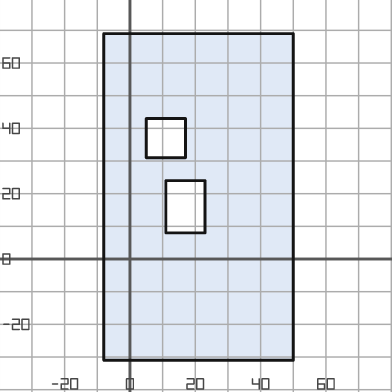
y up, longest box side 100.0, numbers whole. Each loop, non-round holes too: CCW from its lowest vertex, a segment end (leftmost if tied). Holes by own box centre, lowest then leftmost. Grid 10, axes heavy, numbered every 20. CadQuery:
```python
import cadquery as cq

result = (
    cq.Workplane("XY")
    .moveTo(-8.0, -31.0)
    .lineTo(50.0, -31.0)
    .lineTo(50.0, 69.0)
    .lineTo(-8.0, 69.0)
    .close()
    .moveTo(11.0, 8.0)
    .lineTo(23.0, 8.0)
    .lineTo(23.0, 24.0)
    .lineTo(11.0, 24.0)
    .close()
    .moveTo(5.0, 31.0)
    .lineTo(17.0, 31.0)
    .lineTo(17.0, 43.0)
    .lineTo(5.0, 43.0)
    .close()
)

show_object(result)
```